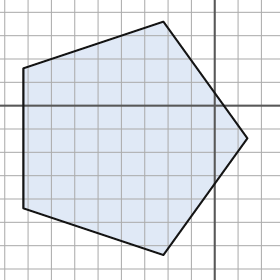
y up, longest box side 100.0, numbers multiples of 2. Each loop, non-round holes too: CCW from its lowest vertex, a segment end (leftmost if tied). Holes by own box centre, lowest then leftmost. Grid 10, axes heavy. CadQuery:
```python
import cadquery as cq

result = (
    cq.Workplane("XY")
    .moveTo(-22.0, -64.0)
    .lineTo(14.0, -14.0)
    .lineTo(-22.0, 36.0)
    .lineTo(-82.0, 16.0)
    .lineTo(-82.0, -44.0)
    .close()
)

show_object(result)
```